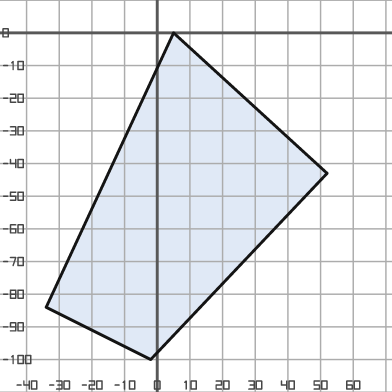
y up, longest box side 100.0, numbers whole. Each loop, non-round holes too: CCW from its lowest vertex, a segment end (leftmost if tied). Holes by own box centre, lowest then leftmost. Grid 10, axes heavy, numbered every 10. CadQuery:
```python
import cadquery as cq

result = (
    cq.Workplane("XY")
    .moveTo(-2.0, -100.0)
    .lineTo(52.0, -43.0)
    .lineTo(5.0, 0.0)
    .lineTo(-34.0, -84.0)
    .close()
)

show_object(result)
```